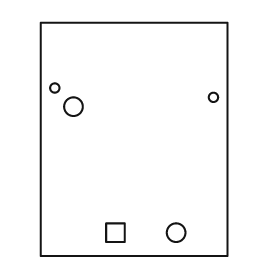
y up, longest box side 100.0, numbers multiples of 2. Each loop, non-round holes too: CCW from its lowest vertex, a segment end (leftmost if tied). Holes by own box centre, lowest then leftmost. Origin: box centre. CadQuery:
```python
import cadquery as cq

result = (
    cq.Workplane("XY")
    .moveTo(-40.0, -50.0)
    .lineTo(40.0, -50.0)
    .lineTo(40.0, 50.0)
    .lineTo(-40.0, 50.0)
    .close()
    .moveTo(-12.0, -44.0)
    .lineTo(-4.0, -44.0)
    .lineTo(-4.0, -36.0)
    .lineTo(-12.0, -36.0)
    .close()
    .moveTo(18.0, -40.0)
    .circle(4.0)
    .moveTo(-26.0, 14.0)
    .circle(4.0)
    .moveTo(34.0, 18.0)
    .circle(2.0)
    .moveTo(-34.0, 22.0)
    .circle(2.0)
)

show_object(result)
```